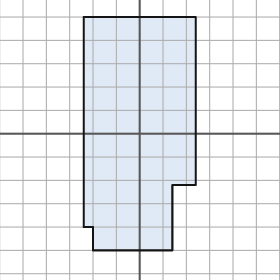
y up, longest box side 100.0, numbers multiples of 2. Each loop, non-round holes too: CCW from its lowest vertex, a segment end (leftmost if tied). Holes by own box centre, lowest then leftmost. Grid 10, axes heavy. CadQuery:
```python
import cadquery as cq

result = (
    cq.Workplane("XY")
    .moveTo(-20.0, -50.0)
    .lineTo(14.0, -50.0)
    .lineTo(14.0, -22.0)
    .lineTo(24.0, -22.0)
    .lineTo(24.0, 50.0)
    .lineTo(-24.0, 50.0)
    .lineTo(-24.0, -40.0)
    .lineTo(-20.0, -40.0)
    .close()
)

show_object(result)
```